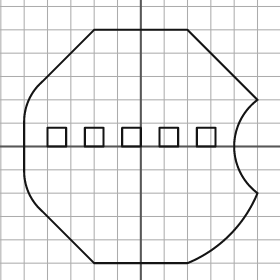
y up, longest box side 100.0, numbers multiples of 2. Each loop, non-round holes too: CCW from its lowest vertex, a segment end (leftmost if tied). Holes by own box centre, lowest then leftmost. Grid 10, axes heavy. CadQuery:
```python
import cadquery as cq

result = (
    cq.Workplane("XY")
    .moveTo(-20.0, -50.0)
    .lineTo(20.0, -50.0)
    .threePointArc((38.0, -38.0), (50.0, -20.0))
    .threePointArc((40.0, 0.0), (50.0, 20.0))
    .lineTo(20.0, 50.0)
    .lineTo(-20.0, 50.0)
    .lineTo(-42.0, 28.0)
    .threePointArc((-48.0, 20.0), (-50.0, 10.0))
    .lineTo(-50.0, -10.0)
    .threePointArc((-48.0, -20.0), (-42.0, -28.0))
    .close()
    .moveTo(-40.0, 0.0)
    .lineTo(-32.0, 0.0)
    .lineTo(-32.0, 8.0)
    .lineTo(-40.0, 8.0)
    .close()
    .moveTo(-24.0, 0.0)
    .lineTo(-16.0, 0.0)
    .lineTo(-16.0, 8.0)
    .lineTo(-24.0, 8.0)
    .close()
    .moveTo(-8.0, 0.0)
    .lineTo(0.0, 0.0)
    .lineTo(0.0, 8.0)
    .lineTo(-8.0, 8.0)
    .close()
    .moveTo(8.0, 0.0)
    .lineTo(16.0, 0.0)
    .lineTo(16.0, 8.0)
    .lineTo(8.0, 8.0)
    .close()
    .moveTo(24.0, 0.0)
    .lineTo(32.0, 0.0)
    .lineTo(32.0, 8.0)
    .lineTo(24.0, 8.0)
    .close()
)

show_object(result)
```